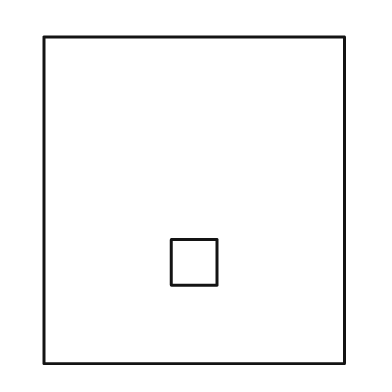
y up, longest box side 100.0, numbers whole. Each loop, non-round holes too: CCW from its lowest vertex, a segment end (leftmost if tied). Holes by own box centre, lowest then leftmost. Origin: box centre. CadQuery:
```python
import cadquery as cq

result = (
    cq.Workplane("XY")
    .moveTo(-46.0, -50.0)
    .lineTo(46.0, -50.0)
    .lineTo(46.0, 50.0)
    .lineTo(-46.0, 50.0)
    .close()
    .moveTo(-7.0, -26.0)
    .lineTo(7.0, -26.0)
    .lineTo(7.0, -12.0)
    .lineTo(-7.0, -12.0)
    .close()
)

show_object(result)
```